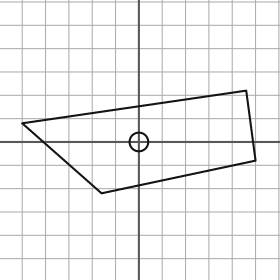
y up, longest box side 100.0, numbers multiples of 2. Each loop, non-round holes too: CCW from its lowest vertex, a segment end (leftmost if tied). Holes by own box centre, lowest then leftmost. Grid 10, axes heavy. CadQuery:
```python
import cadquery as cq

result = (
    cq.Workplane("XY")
    .moveTo(-16.0, -22.0)
    .lineTo(50.0, -8.0)
    .lineTo(46.0, 22.0)
    .lineTo(-50.0, 8.0)
    .close()
    .moveTo(0.0, 0.0)
    .circle(4.0)
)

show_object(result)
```